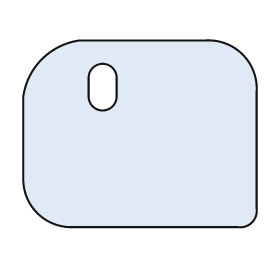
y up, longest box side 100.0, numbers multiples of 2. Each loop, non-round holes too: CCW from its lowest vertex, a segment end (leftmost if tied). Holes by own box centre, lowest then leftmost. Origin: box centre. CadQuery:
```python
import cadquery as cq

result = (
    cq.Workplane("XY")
    .moveTo(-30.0, -40.0)
    .lineTo(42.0, -40.0)
    .threePointArc((48.0, -38.0), (50.0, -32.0))
    .lineTo(50.0, 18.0)
    .threePointArc((44.0, 34.0), (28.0, 40.0))
    .lineTo(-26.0, 40.0)
    .threePointArc((-42.0, 32.0), (-50.0, 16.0))
    .lineTo(-50.0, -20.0)
    .threePointArc((-44.0, -34.0), (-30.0, -40.0))
    .close()
    .moveTo(-22.0, 16.0)
    .threePointArc((-16.0, 10.0), (-10.0, 16.0))
    .lineTo(-10.0, 24.0)
    .threePointArc((-16.0, 30.0), (-22.0, 24.0))
    .close()
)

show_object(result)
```